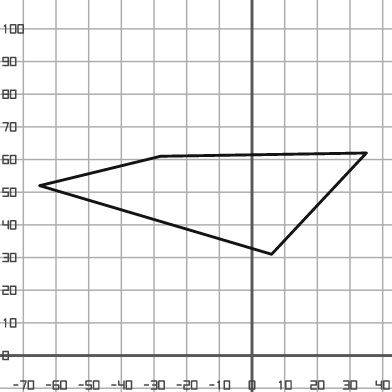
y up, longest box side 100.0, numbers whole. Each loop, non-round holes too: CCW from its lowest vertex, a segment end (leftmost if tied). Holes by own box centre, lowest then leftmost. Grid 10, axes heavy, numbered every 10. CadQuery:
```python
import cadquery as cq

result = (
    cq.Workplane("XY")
    .moveTo(6.0, 31.0)
    .lineTo(35.0, 62.0)
    .lineTo(-28.0, 61.0)
    .lineTo(-65.0, 52.0)
    .close()
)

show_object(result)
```